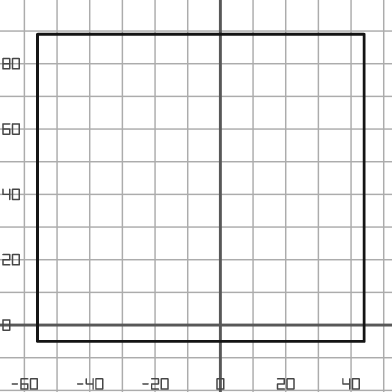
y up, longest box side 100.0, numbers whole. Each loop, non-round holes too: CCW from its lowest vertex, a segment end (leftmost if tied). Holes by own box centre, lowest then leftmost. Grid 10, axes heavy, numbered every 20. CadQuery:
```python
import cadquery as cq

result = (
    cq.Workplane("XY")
    .moveTo(-56.0, -5.0)
    .lineTo(44.0, -5.0)
    .lineTo(44.0, 89.0)
    .lineTo(-56.0, 89.0)
    .close()
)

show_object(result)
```